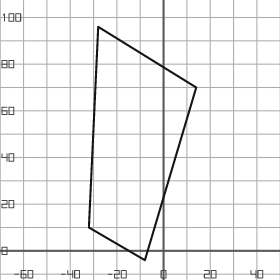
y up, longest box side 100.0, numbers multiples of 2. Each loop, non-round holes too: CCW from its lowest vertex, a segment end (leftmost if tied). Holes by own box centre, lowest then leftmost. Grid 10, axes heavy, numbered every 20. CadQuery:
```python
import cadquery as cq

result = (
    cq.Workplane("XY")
    .moveTo(-8.0, -4.0)
    .lineTo(14.0, 70.0)
    .lineTo(-28.0, 96.0)
    .lineTo(-32.0, 10.0)
    .close()
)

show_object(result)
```